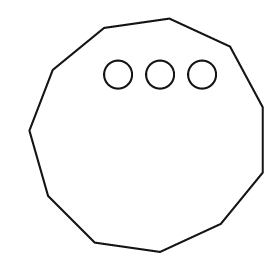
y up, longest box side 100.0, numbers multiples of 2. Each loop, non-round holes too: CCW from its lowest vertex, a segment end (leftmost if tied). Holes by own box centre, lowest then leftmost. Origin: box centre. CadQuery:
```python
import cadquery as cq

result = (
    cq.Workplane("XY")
    .moveTo(6.0, -50.0)
    .lineTo(32.0, -38.0)
    .lineTo(50.0, -16.0)
    .lineTo(50.0, 12.0)
    .lineTo(36.0, 38.0)
    .lineTo(10.0, 50.0)
    .lineTo(-18.0, 46.0)
    .lineTo(-40.0, 28.0)
    .lineTo(-50.0, 2.0)
    .lineTo(-42.0, -26.0)
    .lineTo(-22.0, -46.0)
    .close()
    .moveTo(-12.0, 26.0)
    .circle(6.0)
    .moveTo(6.0, 26.0)
    .circle(6.0)
    .moveTo(24.0, 26.0)
    .circle(6.0)
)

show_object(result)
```